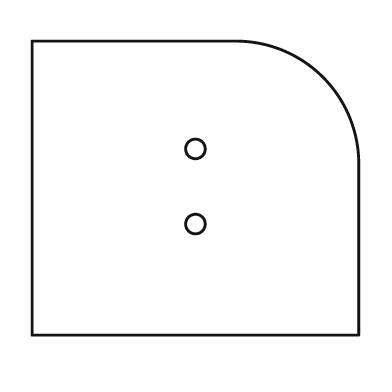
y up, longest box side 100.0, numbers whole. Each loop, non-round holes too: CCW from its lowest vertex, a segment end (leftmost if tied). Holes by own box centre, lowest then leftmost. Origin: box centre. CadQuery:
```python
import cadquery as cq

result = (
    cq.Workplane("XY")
    .moveTo(-50.0, -45.0)
    .lineTo(50.0, -45.0)
    .lineTo(50.0, 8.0)
    .threePointArc((39.0, 34.0), (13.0, 45.0))
    .lineTo(-50.0, 45.0)
    .close()
    .moveTo(0.0, -11.0)
    .circle(3.0)
    .moveTo(0.0, 12.0)
    .circle(3.0)
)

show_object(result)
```